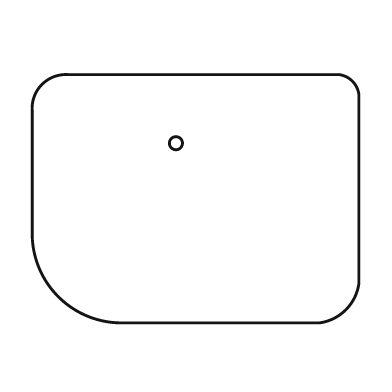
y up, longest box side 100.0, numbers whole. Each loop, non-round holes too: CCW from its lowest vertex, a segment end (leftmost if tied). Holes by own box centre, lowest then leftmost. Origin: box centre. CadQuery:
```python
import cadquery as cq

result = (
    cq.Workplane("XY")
    .moveTo(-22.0, -38.0)
    .lineTo(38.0, -38.0)
    .threePointArc((46.0, -34.0), (50.0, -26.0))
    .lineTo(50.0, 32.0)
    .threePointArc((48.0, 36.0), (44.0, 38.0))
    .lineTo(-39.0, 38.0)
    .threePointArc((-47.0, 35.0), (-50.0, 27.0))
    .lineTo(-50.0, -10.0)
    .threePointArc((-42.0, -30.0), (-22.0, -38.0))
    .close()
    .moveTo(-6.0, 17.0)
    .circle(2.0)
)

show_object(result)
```